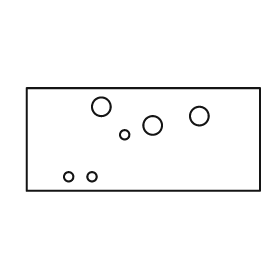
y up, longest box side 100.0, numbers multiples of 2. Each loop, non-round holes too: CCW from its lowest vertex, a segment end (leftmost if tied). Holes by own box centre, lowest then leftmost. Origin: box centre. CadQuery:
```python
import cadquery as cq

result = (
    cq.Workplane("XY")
    .moveTo(-50.0, -22.0)
    .lineTo(50.0, -22.0)
    .lineTo(50.0, 22.0)
    .lineTo(-50.0, 22.0)
    .close()
    .moveTo(-32.0, -16.0)
    .circle(2.0)
    .moveTo(-22.0, -16.0)
    .circle(2.0)
    .moveTo(-8.0, 2.0)
    .circle(2.0)
    .moveTo(4.0, 6.0)
    .circle(4.0)
    .moveTo(24.0, 10.0)
    .circle(4.0)
    .moveTo(-18.0, 14.0)
    .circle(4.0)
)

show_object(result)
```